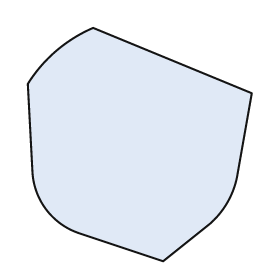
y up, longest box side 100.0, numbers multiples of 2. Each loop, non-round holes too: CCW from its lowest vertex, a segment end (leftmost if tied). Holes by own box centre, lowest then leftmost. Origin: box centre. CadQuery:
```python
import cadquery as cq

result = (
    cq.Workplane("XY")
    .moveTo(10.0, -50.0)
    .lineTo(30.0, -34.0)
    .threePointArc((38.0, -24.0), (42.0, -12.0))
    .lineTo(48.0, 22.0)
    .lineTo(-20.0, 50.0)
    .threePointArc((-36.0, 40.0), (-48.0, 26.0))
    .lineTo(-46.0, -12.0)
    .threePointArc((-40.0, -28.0), (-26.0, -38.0))
    .close()
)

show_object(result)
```